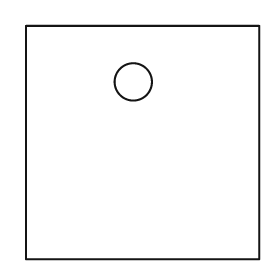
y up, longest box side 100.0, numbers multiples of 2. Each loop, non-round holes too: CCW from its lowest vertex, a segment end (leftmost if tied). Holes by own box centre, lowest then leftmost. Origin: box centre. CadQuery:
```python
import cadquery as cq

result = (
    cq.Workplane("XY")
    .moveTo(-50.0, -50.0)
    .lineTo(50.0, -50.0)
    .lineTo(50.0, 50.0)
    .lineTo(-50.0, 50.0)
    .close()
    .moveTo(-4.0, 26.0)
    .circle(8.0)
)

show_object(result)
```